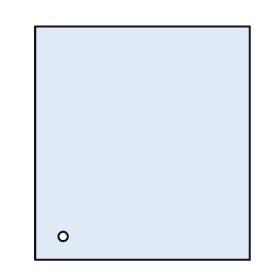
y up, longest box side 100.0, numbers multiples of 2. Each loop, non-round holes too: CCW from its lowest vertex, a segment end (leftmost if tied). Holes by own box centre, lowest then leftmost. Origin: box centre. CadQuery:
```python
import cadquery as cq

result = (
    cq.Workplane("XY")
    .moveTo(-46.0, -50.0)
    .lineTo(46.0, -50.0)
    .lineTo(46.0, 50.0)
    .lineTo(-46.0, 50.0)
    .close()
    .moveTo(-34.0, -40.0)
    .circle(2.0)
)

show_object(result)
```